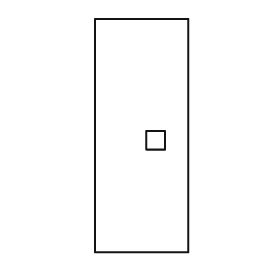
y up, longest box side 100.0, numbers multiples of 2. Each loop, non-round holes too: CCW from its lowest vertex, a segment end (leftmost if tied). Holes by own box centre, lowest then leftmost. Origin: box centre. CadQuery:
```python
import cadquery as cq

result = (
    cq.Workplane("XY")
    .moveTo(-20.0, -50.0)
    .lineTo(20.0, -50.0)
    .lineTo(20.0, 50.0)
    .lineTo(-20.0, 50.0)
    .close()
    .moveTo(2.0, -6.0)
    .lineTo(10.0, -6.0)
    .lineTo(10.0, 2.0)
    .lineTo(2.0, 2.0)
    .close()
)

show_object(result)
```